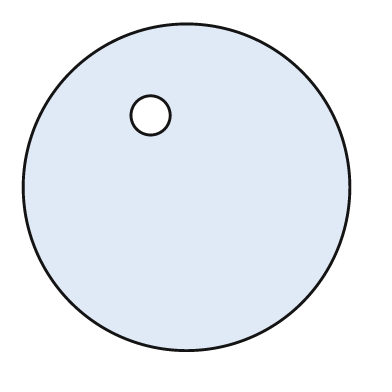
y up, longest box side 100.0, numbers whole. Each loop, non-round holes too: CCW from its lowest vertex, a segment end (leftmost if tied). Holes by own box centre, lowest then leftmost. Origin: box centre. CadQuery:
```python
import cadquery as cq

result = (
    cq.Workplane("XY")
    .moveTo(0.0, 0.0)
    .circle(50.0)
    .moveTo(-11.0, 22.0)
    .circle(6.0)
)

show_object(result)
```